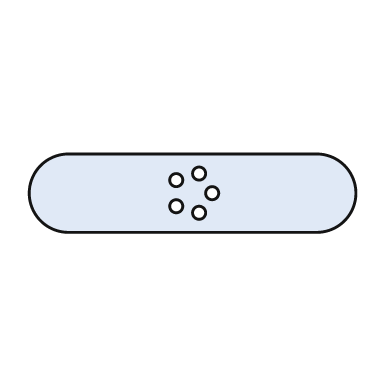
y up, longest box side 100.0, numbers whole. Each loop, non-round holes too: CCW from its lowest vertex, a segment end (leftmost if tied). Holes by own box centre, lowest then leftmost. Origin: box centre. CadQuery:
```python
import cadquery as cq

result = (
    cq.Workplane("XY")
    .moveTo(-38.0, -12.0)
    .lineTo(38.0, -12.0)
    .threePointArc((50.0, 0.0), (38.0, 12.0))
    .lineTo(-38.0, 12.0)
    .threePointArc((-50.0, 0.0), (-38.0, -12.0))
    .close()
    .moveTo(2.0, -6.0)
    .circle(2.0)
    .moveTo(-5.0, -4.0)
    .circle(2.0)
    .moveTo(6.0, 0.0)
    .circle(2.0)
    .moveTo(-5.0, 4.0)
    .circle(2.0)
    .moveTo(2.0, 6.0)
    .circle(2.0)
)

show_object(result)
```